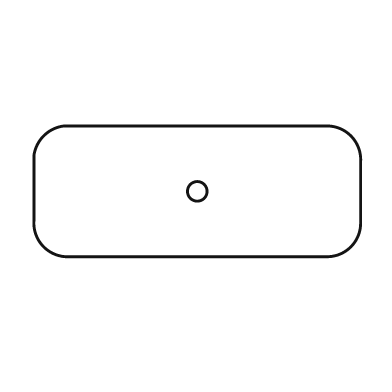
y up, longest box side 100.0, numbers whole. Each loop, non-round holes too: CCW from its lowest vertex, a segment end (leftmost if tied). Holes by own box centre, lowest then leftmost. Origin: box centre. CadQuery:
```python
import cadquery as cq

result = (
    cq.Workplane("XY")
    .moveTo(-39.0, -20.0)
    .lineTo(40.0, -20.0)
    .threePointArc((47.0, -17.0), (50.0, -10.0))
    .lineTo(50.0, 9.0)
    .threePointArc((47.0, 17.0), (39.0, 20.0))
    .lineTo(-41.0, 20.0)
    .threePointArc((-47.0, 17.0), (-50.0, 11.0))
    .lineTo(-50.0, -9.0)
    .threePointArc((-47.0, -17.0), (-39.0, -20.0))
    .close()
    .moveTo(0.0, 0.0)
    .circle(3.0)
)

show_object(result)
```